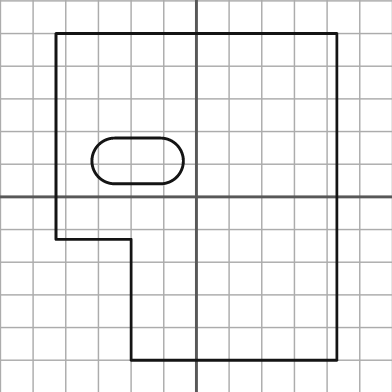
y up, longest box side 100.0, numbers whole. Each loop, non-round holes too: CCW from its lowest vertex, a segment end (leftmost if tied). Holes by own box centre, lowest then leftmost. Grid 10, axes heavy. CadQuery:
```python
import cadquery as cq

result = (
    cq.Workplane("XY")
    .moveTo(-20.0, -50.0)
    .lineTo(43.0, -50.0)
    .lineTo(43.0, 50.0)
    .lineTo(-43.0, 50.0)
    .lineTo(-43.0, -13.0)
    .lineTo(-20.0, -13.0)
    .close()
    .moveTo(-25.0, 4.0)
    .lineTo(-11.0, 4.0)
    .threePointArc((-4.0, 11.0), (-11.0, 18.0))
    .lineTo(-25.0, 18.0)
    .threePointArc((-32.0, 11.0), (-25.0, 4.0))
    .close()
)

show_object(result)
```